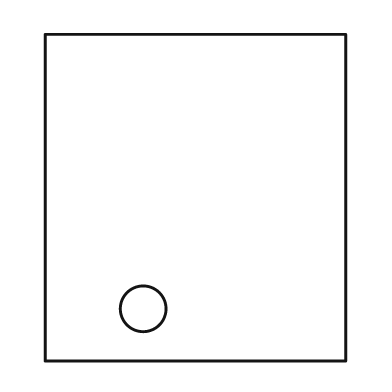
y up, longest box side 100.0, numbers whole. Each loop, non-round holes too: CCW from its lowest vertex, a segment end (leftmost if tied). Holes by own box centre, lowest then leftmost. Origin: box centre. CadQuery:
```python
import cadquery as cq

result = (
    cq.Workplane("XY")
    .moveTo(-46.0, -50.0)
    .lineTo(46.0, -50.0)
    .lineTo(46.0, 50.0)
    .lineTo(-46.0, 50.0)
    .close()
    .moveTo(-16.0, -34.0)
    .circle(7.0)
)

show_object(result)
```